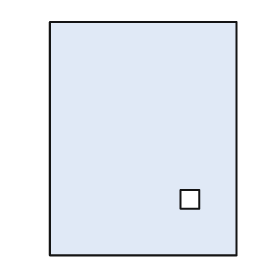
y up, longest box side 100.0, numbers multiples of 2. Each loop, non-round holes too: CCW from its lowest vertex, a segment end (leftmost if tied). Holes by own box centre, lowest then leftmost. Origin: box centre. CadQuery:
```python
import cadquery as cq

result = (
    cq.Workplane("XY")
    .moveTo(-40.0, -50.0)
    .lineTo(40.0, -50.0)
    .lineTo(40.0, 50.0)
    .lineTo(-40.0, 50.0)
    .close()
    .moveTo(16.0, -30.0)
    .lineTo(24.0, -30.0)
    .lineTo(24.0, -22.0)
    .lineTo(16.0, -22.0)
    .close()
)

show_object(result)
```